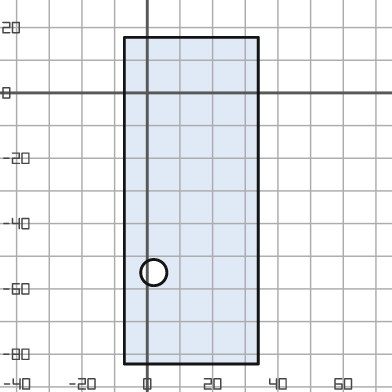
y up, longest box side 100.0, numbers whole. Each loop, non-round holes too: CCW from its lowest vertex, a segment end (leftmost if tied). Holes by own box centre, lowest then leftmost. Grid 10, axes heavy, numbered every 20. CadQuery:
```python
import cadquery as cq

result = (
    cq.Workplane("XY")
    .moveTo(-7.0, -83.0)
    .lineTo(34.0, -83.0)
    .lineTo(34.0, 17.0)
    .lineTo(-7.0, 17.0)
    .close()
    .moveTo(2.0, -55.0)
    .circle(4.0)
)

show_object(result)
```